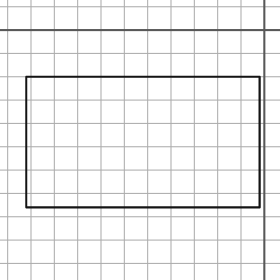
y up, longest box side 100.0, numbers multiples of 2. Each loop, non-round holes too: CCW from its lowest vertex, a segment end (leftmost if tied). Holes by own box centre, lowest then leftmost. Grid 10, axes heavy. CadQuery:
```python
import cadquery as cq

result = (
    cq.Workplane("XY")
    .moveTo(-102.0, -76.0)
    .lineTo(-2.0, -76.0)
    .lineTo(-2.0, -20.0)
    .lineTo(-102.0, -20.0)
    .close()
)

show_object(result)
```